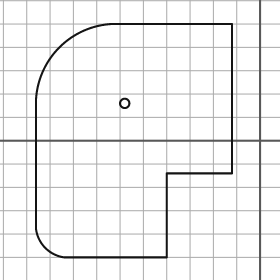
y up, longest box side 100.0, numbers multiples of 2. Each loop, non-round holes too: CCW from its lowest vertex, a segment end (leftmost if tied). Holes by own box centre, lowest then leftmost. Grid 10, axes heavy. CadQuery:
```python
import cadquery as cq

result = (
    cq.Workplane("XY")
    .moveTo(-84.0, -50.0)
    .lineTo(-40.0, -50.0)
    .lineTo(-40.0, -14.0)
    .lineTo(-12.0, -14.0)
    .lineTo(-12.0, 50.0)
    .lineTo(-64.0, 50.0)
    .threePointArc((-86.0, 40.0), (-96.0, 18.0))
    .lineTo(-96.0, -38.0)
    .threePointArc((-92.0, -46.0), (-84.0, -50.0))
    .close()
    .moveTo(-58.0, 16.0)
    .circle(2.0)
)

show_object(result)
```